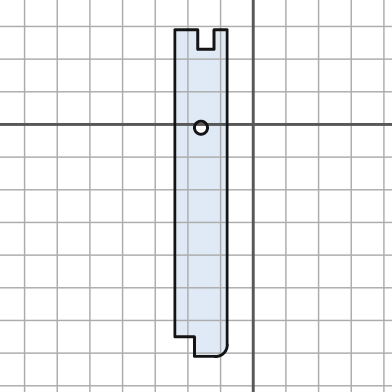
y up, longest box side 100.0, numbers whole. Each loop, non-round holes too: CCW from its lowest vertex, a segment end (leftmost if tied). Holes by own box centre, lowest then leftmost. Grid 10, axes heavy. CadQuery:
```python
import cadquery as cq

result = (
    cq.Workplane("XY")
    .moveTo(-18.0, -71.0)
    .lineTo(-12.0, -71.0)
    .threePointArc((-9.0, -70.0), (-8.0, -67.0))
    .lineTo(-8.0, 29.0)
    .lineTo(-12.0, 29.0)
    .lineTo(-12.0, 23.0)
    .lineTo(-17.0, 23.0)
    .lineTo(-17.0, 29.0)
    .lineTo(-24.0, 29.0)
    .lineTo(-24.0, -65.0)
    .lineTo(-18.0, -65.0)
    .close()
    .moveTo(-16.0, -1.0)
    .circle(2.0)
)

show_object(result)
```